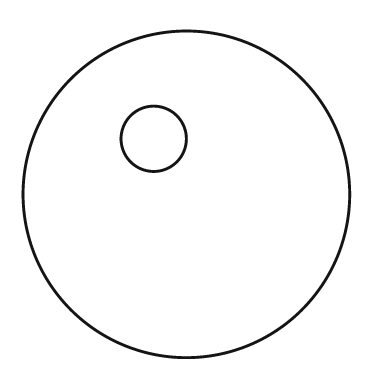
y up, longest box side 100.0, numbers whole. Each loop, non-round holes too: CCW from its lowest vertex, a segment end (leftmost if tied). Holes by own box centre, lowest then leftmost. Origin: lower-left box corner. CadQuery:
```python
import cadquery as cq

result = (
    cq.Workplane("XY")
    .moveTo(50.0, 50.0)
    .circle(50.0)
    .moveTo(40.0, 67.0)
    .circle(10.0)
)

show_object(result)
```